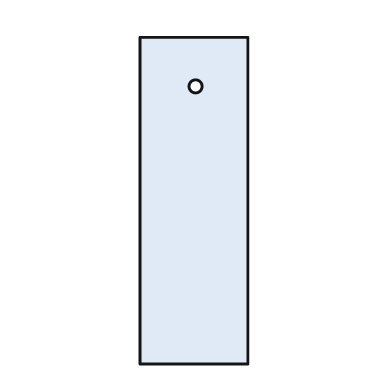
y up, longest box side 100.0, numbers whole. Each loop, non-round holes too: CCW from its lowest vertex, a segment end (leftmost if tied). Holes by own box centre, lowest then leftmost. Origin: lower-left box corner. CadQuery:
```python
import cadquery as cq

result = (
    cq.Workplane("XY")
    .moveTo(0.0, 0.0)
    .lineTo(33.0, 0.0)
    .lineTo(33.0, 100.0)
    .lineTo(0.0, 100.0)
    .close()
    .moveTo(17.0, 85.0)
    .circle(2.0)
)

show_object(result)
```